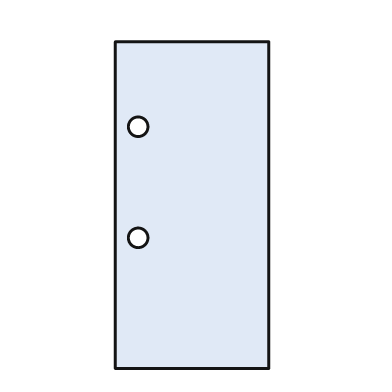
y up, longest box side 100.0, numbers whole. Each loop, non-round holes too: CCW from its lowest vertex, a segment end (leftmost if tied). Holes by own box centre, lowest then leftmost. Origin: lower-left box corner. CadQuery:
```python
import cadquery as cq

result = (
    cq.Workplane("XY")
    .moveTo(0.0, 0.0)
    .lineTo(47.0, 0.0)
    .lineTo(47.0, 100.0)
    .lineTo(0.0, 100.0)
    .close()
    .moveTo(7.0, 40.0)
    .circle(3.0)
    .moveTo(7.0, 74.0)
    .circle(3.0)
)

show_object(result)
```